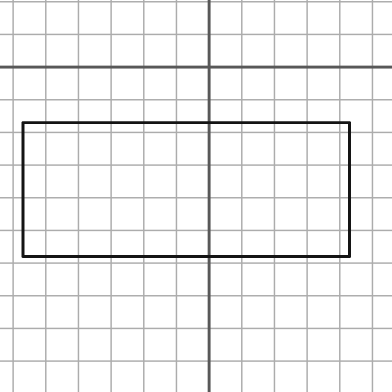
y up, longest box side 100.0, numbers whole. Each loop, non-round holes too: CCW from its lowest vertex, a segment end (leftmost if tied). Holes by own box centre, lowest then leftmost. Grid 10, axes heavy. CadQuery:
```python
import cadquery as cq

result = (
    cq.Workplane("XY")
    .moveTo(-57.0, -58.0)
    .lineTo(43.0, -58.0)
    .lineTo(43.0, -17.0)
    .lineTo(-57.0, -17.0)
    .close()
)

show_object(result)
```